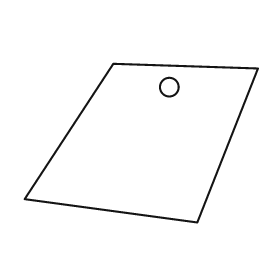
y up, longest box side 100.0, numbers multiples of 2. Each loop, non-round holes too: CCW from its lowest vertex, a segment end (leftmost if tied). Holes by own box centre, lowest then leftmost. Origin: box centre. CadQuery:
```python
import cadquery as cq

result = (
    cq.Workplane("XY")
    .moveTo(24.0, -34.0)
    .lineTo(50.0, 32.0)
    .lineTo(-12.0, 34.0)
    .lineTo(-50.0, -24.0)
    .close()
    .moveTo(12.0, 24.0)
    .circle(4.0)
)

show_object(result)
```